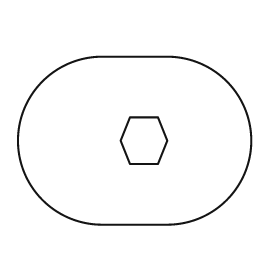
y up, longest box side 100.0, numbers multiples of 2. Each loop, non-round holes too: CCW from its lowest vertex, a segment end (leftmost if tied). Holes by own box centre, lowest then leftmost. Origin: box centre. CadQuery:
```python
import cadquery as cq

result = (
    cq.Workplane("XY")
    .moveTo(-14.0, -36.0)
    .lineTo(14.0, -36.0)
    .threePointArc((50.0, 0.0), (14.0, 36.0))
    .lineTo(-14.0, 36.0)
    .threePointArc((-50.0, 0.0), (-14.0, -36.0))
    .close()
    .moveTo(-2.0, -10.0)
    .lineTo(10.0, -10.0)
    .lineTo(14.0, 0.0)
    .lineTo(10.0, 10.0)
    .lineTo(-2.0, 10.0)
    .lineTo(-6.0, 0.0)
    .close()
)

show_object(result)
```